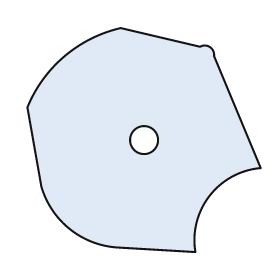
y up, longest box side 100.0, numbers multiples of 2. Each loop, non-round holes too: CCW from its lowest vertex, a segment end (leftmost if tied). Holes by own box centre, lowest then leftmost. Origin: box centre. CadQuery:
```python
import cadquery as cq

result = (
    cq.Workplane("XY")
    .moveTo(22.0, -48.0)
    .threePointArc((28.0, -24.0), (50.0, -12.0))
    .lineTo(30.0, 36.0)
    .threePointArc((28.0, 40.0), (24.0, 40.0))
    .lineTo(-10.0, 48.0)
    .threePointArc((-34.0, 36.0), (-50.0, 14.0))
    .lineTo(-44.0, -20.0)
    .threePointArc((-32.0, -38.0), (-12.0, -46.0))
    .close()
    .moveTo(0.0, 0.0)
    .circle(6.0)
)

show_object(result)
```